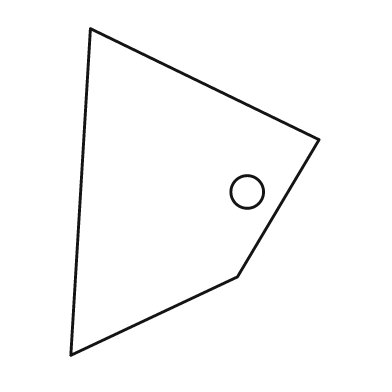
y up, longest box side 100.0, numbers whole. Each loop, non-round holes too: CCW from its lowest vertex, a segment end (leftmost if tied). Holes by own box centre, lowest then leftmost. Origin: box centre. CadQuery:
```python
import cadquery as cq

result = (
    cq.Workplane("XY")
    .moveTo(-38.0, -50.0)
    .lineTo(13.0, -26.0)
    .lineTo(38.0, 16.0)
    .lineTo(-32.0, 50.0)
    .close()
    .moveTo(16.0, 0.0)
    .circle(5.0)
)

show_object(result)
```